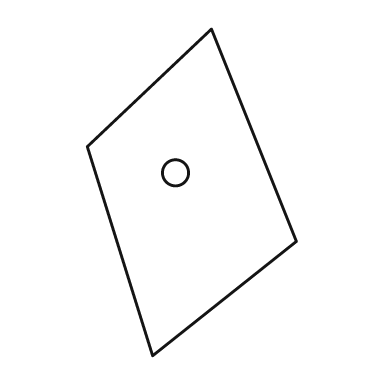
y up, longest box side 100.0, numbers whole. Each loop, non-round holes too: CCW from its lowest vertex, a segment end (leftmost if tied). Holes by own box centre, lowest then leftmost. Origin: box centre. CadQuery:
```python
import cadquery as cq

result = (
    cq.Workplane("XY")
    .moveTo(-12.0, -50.0)
    .lineTo(32.0, -15.0)
    .lineTo(6.0, 50.0)
    .lineTo(-32.0, 14.0)
    .close()
    .moveTo(-5.0, 6.0)
    .circle(4.0)
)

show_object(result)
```